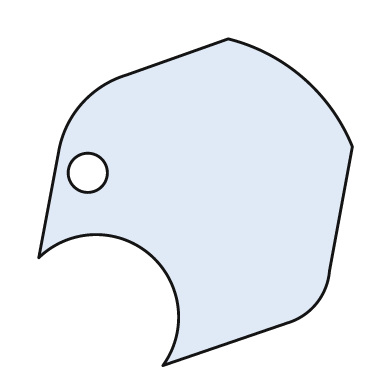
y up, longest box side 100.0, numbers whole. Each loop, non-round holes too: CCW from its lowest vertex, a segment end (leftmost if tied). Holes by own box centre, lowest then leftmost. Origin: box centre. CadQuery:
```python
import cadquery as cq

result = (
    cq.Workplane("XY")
    .moveTo(-10.0, -50.0)
    .lineTo(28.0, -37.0)
    .threePointArc((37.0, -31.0), (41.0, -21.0))
    .lineTo(48.0, 17.0)
    .threePointArc((33.0, 38.0), (10.0, 50.0))
    .lineTo(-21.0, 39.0)
    .threePointArc((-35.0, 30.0), (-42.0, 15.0))
    .lineTo(-48.0, -17.0)
    .threePointArc((-14.0, -16.0), (-10.0, -50.0))
    .close()
    .moveTo(-33.0, 9.0)
    .circle(6.0)
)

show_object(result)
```